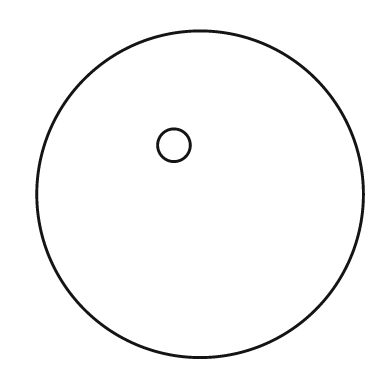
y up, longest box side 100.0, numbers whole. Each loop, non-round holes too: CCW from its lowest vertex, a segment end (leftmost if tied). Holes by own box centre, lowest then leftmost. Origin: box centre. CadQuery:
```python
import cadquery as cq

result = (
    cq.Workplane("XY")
    .moveTo(0.0, 0.0)
    .circle(50.0)
    .moveTo(-8.0, 15.0)
    .circle(5.0)
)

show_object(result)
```